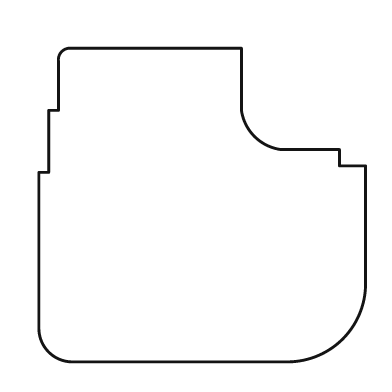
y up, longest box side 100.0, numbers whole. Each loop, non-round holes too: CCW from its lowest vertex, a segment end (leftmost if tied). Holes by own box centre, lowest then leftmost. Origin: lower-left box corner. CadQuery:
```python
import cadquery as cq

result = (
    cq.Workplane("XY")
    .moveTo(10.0, 0.0)
    .lineTo(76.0, 0.0)
    .threePointArc((93.0, 7.0), (100.0, 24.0))
    .lineTo(100.0, 60.0)
    .lineTo(92.0, 60.0)
    .lineTo(92.0, 65.0)
    .lineTo(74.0, 65.0)
    .threePointArc((66.0, 69.0), (62.0, 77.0))
    .lineTo(62.0, 96.0)
    .lineTo(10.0, 96.0)
    .threePointArc((7.0, 95.0), (6.0, 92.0))
    .lineTo(6.0, 77.0)
    .lineTo(3.0, 77.0)
    .lineTo(3.0, 58.0)
    .lineTo(0.0, 58.0)
    .lineTo(0.0, 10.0)
    .threePointArc((3.0, 3.0), (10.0, 0.0))
    .close()
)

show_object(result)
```